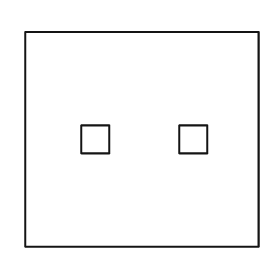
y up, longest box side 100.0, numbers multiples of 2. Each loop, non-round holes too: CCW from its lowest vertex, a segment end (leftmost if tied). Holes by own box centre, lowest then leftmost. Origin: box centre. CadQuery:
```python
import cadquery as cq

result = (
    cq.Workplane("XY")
    .moveTo(-50.0, -46.0)
    .lineTo(50.0, -46.0)
    .lineTo(50.0, 46.0)
    .lineTo(-50.0, 46.0)
    .close()
    .moveTo(-26.0, -6.0)
    .lineTo(-14.0, -6.0)
    .lineTo(-14.0, 6.0)
    .lineTo(-26.0, 6.0)
    .close()
    .moveTo(16.0, -6.0)
    .lineTo(28.0, -6.0)
    .lineTo(28.0, 6.0)
    .lineTo(16.0, 6.0)
    .close()
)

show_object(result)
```